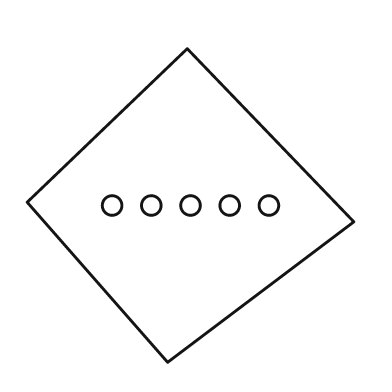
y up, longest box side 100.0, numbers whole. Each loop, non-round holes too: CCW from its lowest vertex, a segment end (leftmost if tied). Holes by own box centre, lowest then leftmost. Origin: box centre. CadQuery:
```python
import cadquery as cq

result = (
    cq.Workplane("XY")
    .moveTo(-7.0, -48.0)
    .lineTo(50.0, -5.0)
    .lineTo(-1.0, 48.0)
    .lineTo(-50.0, 1.0)
    .close()
    .moveTo(-24.0, 0.0)
    .circle(3.0)
    .moveTo(-12.0, 0.0)
    .circle(3.0)
    .moveTo(0.0, 0.0)
    .circle(3.0)
    .moveTo(12.0, 0.0)
    .circle(3.0)
    .moveTo(24.0, 0.0)
    .circle(3.0)
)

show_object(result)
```